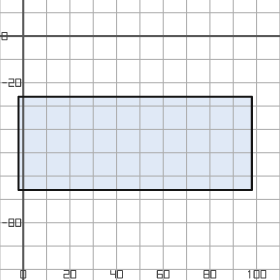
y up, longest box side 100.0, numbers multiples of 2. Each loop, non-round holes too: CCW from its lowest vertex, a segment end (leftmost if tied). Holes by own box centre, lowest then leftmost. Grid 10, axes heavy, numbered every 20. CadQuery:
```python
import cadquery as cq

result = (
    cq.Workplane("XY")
    .moveTo(-2.0, -66.0)
    .lineTo(98.0, -66.0)
    .lineTo(98.0, -26.0)
    .lineTo(-2.0, -26.0)
    .close()
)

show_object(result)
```